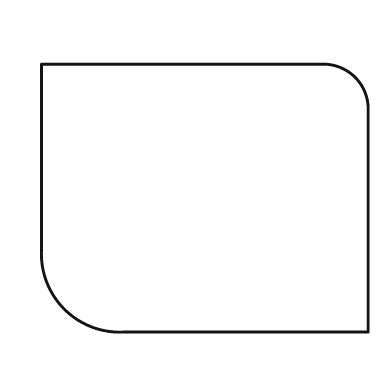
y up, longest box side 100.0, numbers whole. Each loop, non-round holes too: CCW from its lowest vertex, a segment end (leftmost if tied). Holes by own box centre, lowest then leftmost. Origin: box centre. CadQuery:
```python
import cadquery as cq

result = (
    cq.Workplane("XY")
    .moveTo(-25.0, -41.0)
    .lineTo(50.0, -41.0)
    .lineTo(50.0, 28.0)
    .threePointArc((46.0, 37.0), (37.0, 41.0))
    .lineTo(-50.0, 41.0)
    .lineTo(-50.0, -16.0)
    .threePointArc((-43.0, -34.0), (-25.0, -41.0))
    .close()
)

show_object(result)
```